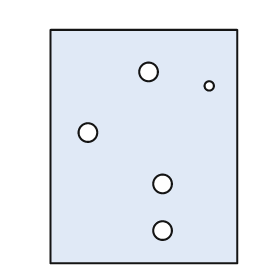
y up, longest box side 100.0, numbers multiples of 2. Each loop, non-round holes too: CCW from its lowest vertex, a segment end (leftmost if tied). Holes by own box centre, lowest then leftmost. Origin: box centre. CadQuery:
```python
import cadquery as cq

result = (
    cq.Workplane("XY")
    .moveTo(-40.0, -50.0)
    .lineTo(40.0, -50.0)
    .lineTo(40.0, 50.0)
    .lineTo(-40.0, 50.0)
    .close()
    .moveTo(8.0, -36.0)
    .circle(4.0)
    .moveTo(8.0, -16.0)
    .circle(4.0)
    .moveTo(-24.0, 6.0)
    .circle(4.0)
    .moveTo(28.0, 26.0)
    .circle(2.0)
    .moveTo(2.0, 32.0)
    .circle(4.0)
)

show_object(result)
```